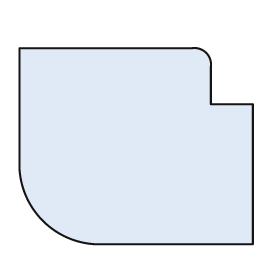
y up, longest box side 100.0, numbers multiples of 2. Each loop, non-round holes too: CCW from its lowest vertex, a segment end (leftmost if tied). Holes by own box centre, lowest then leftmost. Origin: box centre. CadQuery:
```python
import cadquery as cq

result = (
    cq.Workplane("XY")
    .moveTo(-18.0, -42.0)
    .lineTo(50.0, -42.0)
    .lineTo(50.0, 18.0)
    .lineTo(32.0, 18.0)
    .lineTo(32.0, 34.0)
    .threePointArc((30.0, 40.0), (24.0, 42.0))
    .lineTo(-50.0, 42.0)
    .lineTo(-50.0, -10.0)
    .threePointArc((-40.0, -32.0), (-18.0, -42.0))
    .close()
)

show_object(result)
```